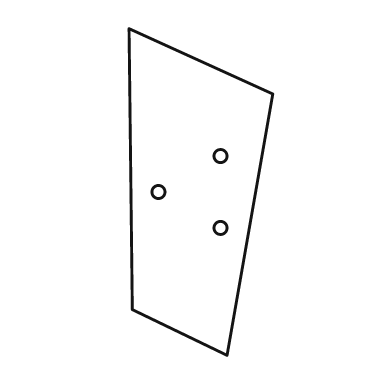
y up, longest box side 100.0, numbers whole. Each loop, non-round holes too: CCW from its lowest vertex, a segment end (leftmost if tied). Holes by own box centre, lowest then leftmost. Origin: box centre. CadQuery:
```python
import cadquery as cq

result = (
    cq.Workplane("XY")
    .moveTo(8.0, -50.0)
    .lineTo(22.0, 30.0)
    .lineTo(-22.0, 50.0)
    .lineTo(-21.0, -36.0)
    .close()
    .moveTo(6.0, -11.0)
    .circle(2.0)
    .moveTo(-13.0, 0.0)
    .circle(2.0)
    .moveTo(6.0, 11.0)
    .circle(2.0)
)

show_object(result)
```